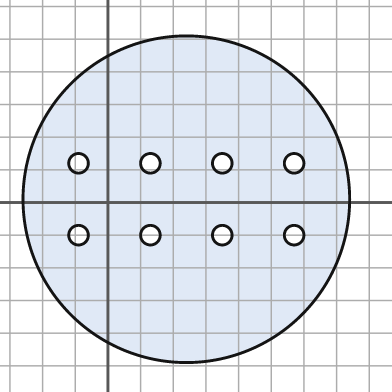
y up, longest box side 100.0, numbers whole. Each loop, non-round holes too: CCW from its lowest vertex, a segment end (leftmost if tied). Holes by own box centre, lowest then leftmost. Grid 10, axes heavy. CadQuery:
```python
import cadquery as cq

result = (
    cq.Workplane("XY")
    .moveTo(24.0, 1.0)
    .circle(50.0)
    .moveTo(-9.0, -10.0)
    .circle(3.0)
    .moveTo(13.0, -10.0)
    .circle(3.0)
    .moveTo(35.0, -10.0)
    .circle(3.0)
    .moveTo(57.0, -10.0)
    .circle(3.0)
    .moveTo(-9.0, 12.0)
    .circle(3.0)
    .moveTo(13.0, 12.0)
    .circle(3.0)
    .moveTo(35.0, 12.0)
    .circle(3.0)
    .moveTo(57.0, 12.0)
    .circle(3.0)
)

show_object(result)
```